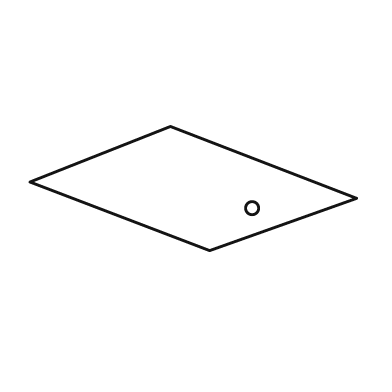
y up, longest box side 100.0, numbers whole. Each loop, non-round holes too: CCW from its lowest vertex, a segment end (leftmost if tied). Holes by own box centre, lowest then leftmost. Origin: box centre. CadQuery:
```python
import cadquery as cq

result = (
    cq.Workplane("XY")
    .moveTo(5.0, -19.0)
    .lineTo(50.0, -3.0)
    .lineTo(-7.0, 19.0)
    .lineTo(-50.0, 2.0)
    .close()
    .moveTo(18.0, -6.0)
    .circle(2.0)
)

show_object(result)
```